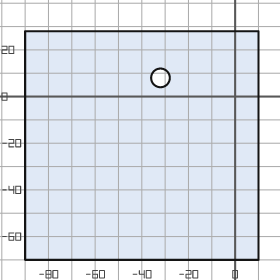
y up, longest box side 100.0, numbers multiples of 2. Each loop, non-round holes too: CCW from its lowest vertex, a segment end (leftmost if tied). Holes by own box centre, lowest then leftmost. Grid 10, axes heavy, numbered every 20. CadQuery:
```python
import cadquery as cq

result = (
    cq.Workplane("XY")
    .moveTo(-90.0, -70.0)
    .lineTo(10.0, -70.0)
    .lineTo(10.0, 28.0)
    .lineTo(-90.0, 28.0)
    .close()
    .moveTo(-32.0, 8.0)
    .circle(4.0)
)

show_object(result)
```